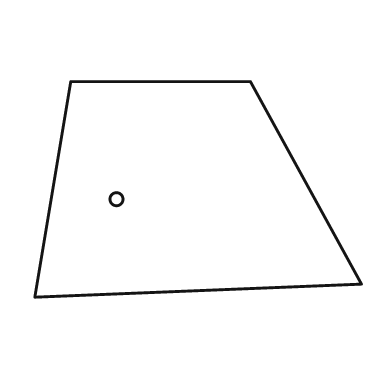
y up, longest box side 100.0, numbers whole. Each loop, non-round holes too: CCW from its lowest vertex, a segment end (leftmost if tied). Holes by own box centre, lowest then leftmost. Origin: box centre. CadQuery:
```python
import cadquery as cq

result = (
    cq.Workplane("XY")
    .moveTo(-50.0, -33.0)
    .lineTo(50.0, -29.0)
    .lineTo(16.0, 33.0)
    .lineTo(-39.0, 33.0)
    .close()
    .moveTo(-25.0, -3.0)
    .circle(2.0)
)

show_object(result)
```